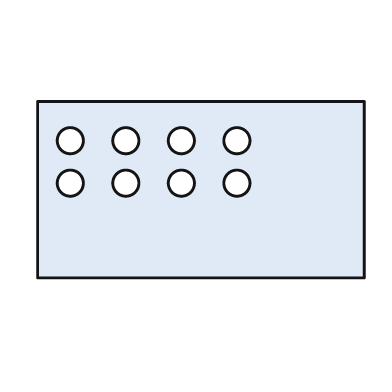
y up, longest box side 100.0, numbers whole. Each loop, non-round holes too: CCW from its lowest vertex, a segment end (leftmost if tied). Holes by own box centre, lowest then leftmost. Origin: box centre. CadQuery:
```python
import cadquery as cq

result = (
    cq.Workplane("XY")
    .moveTo(-50.0, -27.0)
    .lineTo(50.0, -27.0)
    .lineTo(50.0, 27.0)
    .lineTo(-50.0, 27.0)
    .close()
    .moveTo(-40.0, 2.0)
    .circle(4.0)
    .moveTo(-23.0, 2.0)
    .circle(4.0)
    .moveTo(-6.0, 2.0)
    .circle(4.0)
    .moveTo(11.0, 2.0)
    .circle(4.0)
    .moveTo(-40.0, 15.0)
    .circle(4.0)
    .moveTo(-23.0, 15.0)
    .circle(4.0)
    .moveTo(-6.0, 15.0)
    .circle(4.0)
    .moveTo(11.0, 15.0)
    .circle(4.0)
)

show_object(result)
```